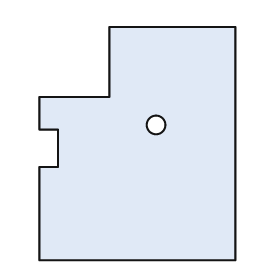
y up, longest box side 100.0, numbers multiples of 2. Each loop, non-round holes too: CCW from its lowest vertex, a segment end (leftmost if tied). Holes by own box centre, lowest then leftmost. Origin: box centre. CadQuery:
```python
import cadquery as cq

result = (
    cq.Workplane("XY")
    .moveTo(-42.0, -50.0)
    .lineTo(42.0, -50.0)
    .lineTo(42.0, 50.0)
    .lineTo(-12.0, 50.0)
    .lineTo(-12.0, 20.0)
    .lineTo(-42.0, 20.0)
    .lineTo(-42.0, 6.0)
    .lineTo(-34.0, 6.0)
    .lineTo(-34.0, -10.0)
    .lineTo(-42.0, -10.0)
    .close()
    .moveTo(8.0, 8.0)
    .circle(4.0)
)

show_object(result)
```